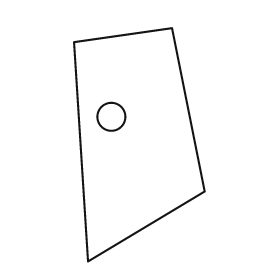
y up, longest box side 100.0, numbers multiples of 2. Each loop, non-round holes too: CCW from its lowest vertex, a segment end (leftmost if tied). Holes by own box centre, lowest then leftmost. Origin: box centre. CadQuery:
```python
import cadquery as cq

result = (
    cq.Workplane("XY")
    .moveTo(-22.0, -50.0)
    .lineTo(28.0, -20.0)
    .lineTo(14.0, 50.0)
    .lineTo(-28.0, 44.0)
    .close()
    .moveTo(-12.0, 12.0)
    .circle(6.0)
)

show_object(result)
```